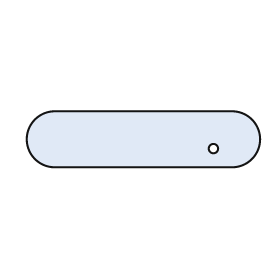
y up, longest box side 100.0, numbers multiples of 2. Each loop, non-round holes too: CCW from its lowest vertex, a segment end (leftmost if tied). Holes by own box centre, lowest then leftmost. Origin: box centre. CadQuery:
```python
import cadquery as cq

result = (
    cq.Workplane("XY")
    .moveTo(-38.0, -12.0)
    .lineTo(38.0, -12.0)
    .threePointArc((50.0, 0.0), (38.0, 12.0))
    .lineTo(-38.0, 12.0)
    .threePointArc((-50.0, 0.0), (-38.0, -12.0))
    .close()
    .moveTo(30.0, -4.0)
    .circle(2.0)
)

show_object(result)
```